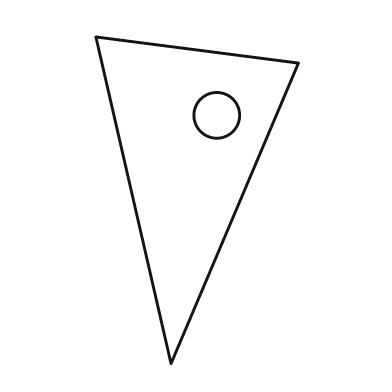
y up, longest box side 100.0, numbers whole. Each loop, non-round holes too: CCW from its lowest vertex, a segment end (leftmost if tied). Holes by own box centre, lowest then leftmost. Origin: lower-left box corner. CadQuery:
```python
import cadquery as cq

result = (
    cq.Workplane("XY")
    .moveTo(23.0, 0.0)
    .lineTo(62.0, 92.0)
    .lineTo(0.0, 100.0)
    .close()
    .moveTo(37.0, 76.0)
    .circle(7.0)
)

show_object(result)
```